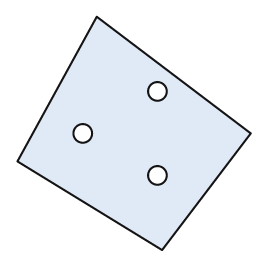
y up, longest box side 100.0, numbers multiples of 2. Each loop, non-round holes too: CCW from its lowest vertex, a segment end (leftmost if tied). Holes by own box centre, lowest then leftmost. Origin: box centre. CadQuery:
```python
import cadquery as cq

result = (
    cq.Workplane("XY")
    .moveTo(12.0, -50.0)
    .lineTo(50.0, 0.0)
    .lineTo(-16.0, 50.0)
    .lineTo(-50.0, -12.0)
    .close()
    .moveTo(10.0, -18.0)
    .circle(4.0)
    .moveTo(-22.0, 0.0)
    .circle(4.0)
    .moveTo(10.0, 18.0)
    .circle(4.0)
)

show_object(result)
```